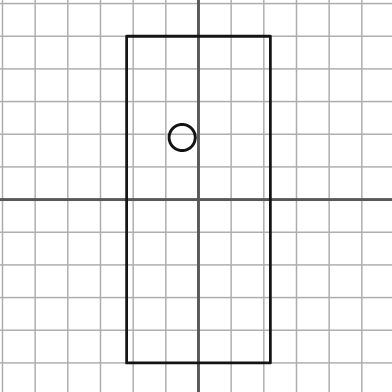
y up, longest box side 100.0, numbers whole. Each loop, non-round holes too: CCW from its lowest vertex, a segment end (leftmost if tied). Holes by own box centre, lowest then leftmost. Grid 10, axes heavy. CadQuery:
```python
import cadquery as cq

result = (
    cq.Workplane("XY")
    .moveTo(-22.0, -50.0)
    .lineTo(22.0, -50.0)
    .lineTo(22.0, 50.0)
    .lineTo(-22.0, 50.0)
    .close()
    .moveTo(-5.0, 19.0)
    .circle(4.0)
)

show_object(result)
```